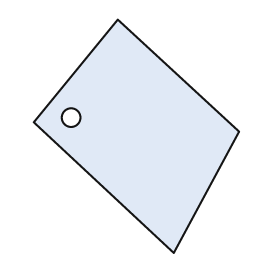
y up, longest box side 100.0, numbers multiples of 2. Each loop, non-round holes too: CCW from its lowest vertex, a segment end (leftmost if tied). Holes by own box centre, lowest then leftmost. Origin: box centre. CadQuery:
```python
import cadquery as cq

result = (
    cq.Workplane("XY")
    .moveTo(16.0, -50.0)
    .lineTo(44.0, 2.0)
    .lineTo(-8.0, 50.0)
    .lineTo(-44.0, 6.0)
    .close()
    .moveTo(-28.0, 8.0)
    .circle(4.0)
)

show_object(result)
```